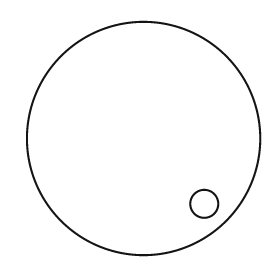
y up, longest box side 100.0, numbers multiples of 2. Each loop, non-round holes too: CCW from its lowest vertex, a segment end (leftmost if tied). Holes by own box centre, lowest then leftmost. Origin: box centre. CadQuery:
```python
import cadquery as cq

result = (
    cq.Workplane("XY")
    .moveTo(0.0, 0.0)
    .circle(50.0)
    .moveTo(26.0, -28.0)
    .circle(6.0)
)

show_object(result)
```